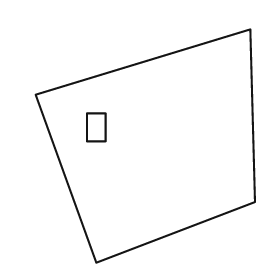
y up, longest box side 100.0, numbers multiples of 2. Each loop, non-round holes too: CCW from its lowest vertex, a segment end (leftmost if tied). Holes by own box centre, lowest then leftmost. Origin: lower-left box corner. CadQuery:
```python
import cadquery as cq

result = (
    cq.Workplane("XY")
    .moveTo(26.0, 0.0)
    .lineTo(94.0, 26.0)
    .lineTo(92.0, 100.0)
    .lineTo(0.0, 72.0)
    .close()
    .moveTo(22.0, 52.0)
    .lineTo(30.0, 52.0)
    .lineTo(30.0, 64.0)
    .lineTo(22.0, 64.0)
    .close()
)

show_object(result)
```